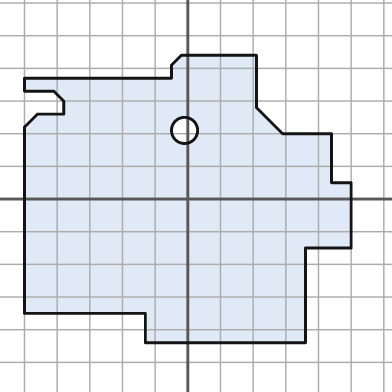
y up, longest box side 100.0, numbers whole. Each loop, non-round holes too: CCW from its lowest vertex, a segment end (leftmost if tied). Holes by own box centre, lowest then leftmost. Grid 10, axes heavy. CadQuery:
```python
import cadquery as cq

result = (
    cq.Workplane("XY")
    .moveTo(-13.0, -44.0)
    .lineTo(36.0, -44.0)
    .lineTo(36.0, -15.0)
    .lineTo(50.0, -15.0)
    .lineTo(50.0, 5.0)
    .lineTo(44.0, 5.0)
    .lineTo(44.0, 20.0)
    .lineTo(29.0, 20.0)
    .lineTo(21.0, 28.0)
    .lineTo(21.0, 44.0)
    .lineTo(-2.0, 44.0)
    .lineTo(-5.0, 41.0)
    .lineTo(-5.0, 37.0)
    .lineTo(-50.0, 37.0)
    .lineTo(-50.0, 33.0)
    .lineTo(-41.0, 33.0)
    .lineTo(-38.0, 30.0)
    .lineTo(-38.0, 26.0)
    .lineTo(-46.0, 26.0)
    .lineTo(-50.0, 22.0)
    .lineTo(-50.0, -35.0)
    .lineTo(-13.0, -35.0)
    .close()
    .moveTo(-1.0, 21.0)
    .circle(4.0)
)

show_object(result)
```